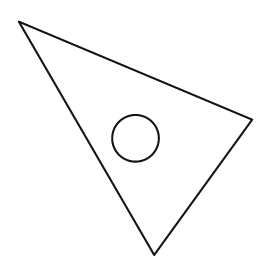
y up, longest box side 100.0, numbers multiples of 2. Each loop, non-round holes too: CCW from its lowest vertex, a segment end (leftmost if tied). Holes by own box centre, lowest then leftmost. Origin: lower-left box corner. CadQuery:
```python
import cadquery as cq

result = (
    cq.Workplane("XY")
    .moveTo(58.0, 0.0)
    .lineTo(100.0, 58.0)
    .lineTo(0.0, 100.0)
    .close()
    .moveTo(50.0, 50.0)
    .circle(10.0)
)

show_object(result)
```